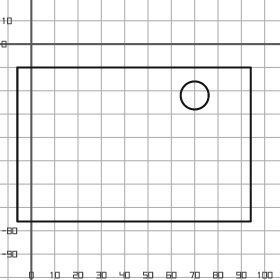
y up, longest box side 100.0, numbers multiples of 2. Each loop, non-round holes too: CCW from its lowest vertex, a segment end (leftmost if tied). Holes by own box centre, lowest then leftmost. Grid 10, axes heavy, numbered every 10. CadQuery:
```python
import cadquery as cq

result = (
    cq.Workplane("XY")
    .moveTo(-6.0, -76.0)
    .lineTo(94.0, -76.0)
    .lineTo(94.0, -10.0)
    .lineTo(-6.0, -10.0)
    .close()
    .moveTo(70.0, -22.0)
    .circle(6.0)
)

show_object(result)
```